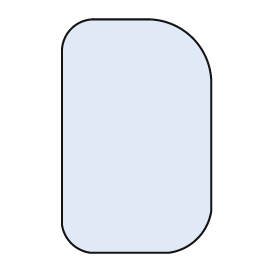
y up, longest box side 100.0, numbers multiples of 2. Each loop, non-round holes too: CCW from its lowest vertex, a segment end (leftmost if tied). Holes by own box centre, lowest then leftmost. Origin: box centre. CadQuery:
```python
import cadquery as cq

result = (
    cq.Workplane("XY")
    .moveTo(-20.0, -50.0)
    .lineTo(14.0, -50.0)
    .threePointArc((26.0, -44.0), (32.0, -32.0))
    .lineTo(32.0, 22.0)
    .threePointArc((24.0, 42.0), (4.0, 50.0))
    .lineTo(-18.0, 50.0)
    .threePointArc((-28.0, 46.0), (-32.0, 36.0))
    .lineTo(-32.0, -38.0)
    .threePointArc((-28.0, -46.0), (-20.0, -50.0))
    .close()
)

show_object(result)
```